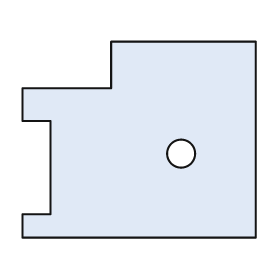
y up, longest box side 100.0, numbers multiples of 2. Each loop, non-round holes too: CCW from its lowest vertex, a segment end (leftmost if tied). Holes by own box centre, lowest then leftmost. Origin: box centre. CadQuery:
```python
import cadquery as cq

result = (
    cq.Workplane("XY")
    .moveTo(-50.0, -42.0)
    .lineTo(50.0, -42.0)
    .lineTo(50.0, 42.0)
    .lineTo(-12.0, 42.0)
    .lineTo(-12.0, 22.0)
    .lineTo(-50.0, 22.0)
    .lineTo(-50.0, 8.0)
    .lineTo(-38.0, 8.0)
    .lineTo(-38.0, -32.0)
    .lineTo(-50.0, -32.0)
    .close()
    .moveTo(18.0, -6.0)
    .circle(6.0)
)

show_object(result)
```